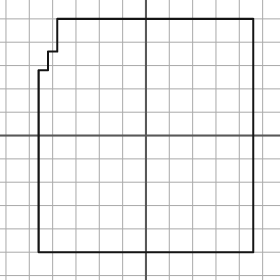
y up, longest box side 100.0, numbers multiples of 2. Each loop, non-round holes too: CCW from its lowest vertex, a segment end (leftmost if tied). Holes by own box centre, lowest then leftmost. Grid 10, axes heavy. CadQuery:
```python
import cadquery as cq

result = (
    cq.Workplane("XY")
    .moveTo(-46.0, -50.0)
    .lineTo(46.0, -50.0)
    .lineTo(46.0, 50.0)
    .lineTo(-38.0, 50.0)
    .lineTo(-38.0, 36.0)
    .lineTo(-42.0, 36.0)
    .lineTo(-42.0, 28.0)
    .lineTo(-46.0, 28.0)
    .close()
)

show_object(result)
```